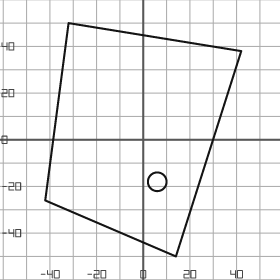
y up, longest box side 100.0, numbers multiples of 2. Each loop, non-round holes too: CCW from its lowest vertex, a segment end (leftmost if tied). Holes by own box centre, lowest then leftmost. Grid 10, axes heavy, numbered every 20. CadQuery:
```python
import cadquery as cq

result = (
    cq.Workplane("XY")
    .moveTo(14.0, -50.0)
    .lineTo(42.0, 38.0)
    .lineTo(-32.0, 50.0)
    .lineTo(-42.0, -26.0)
    .close()
    .moveTo(6.0, -18.0)
    .circle(4.0)
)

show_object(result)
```